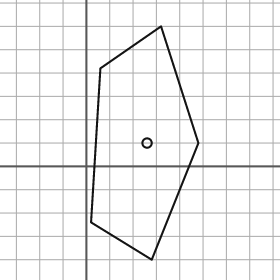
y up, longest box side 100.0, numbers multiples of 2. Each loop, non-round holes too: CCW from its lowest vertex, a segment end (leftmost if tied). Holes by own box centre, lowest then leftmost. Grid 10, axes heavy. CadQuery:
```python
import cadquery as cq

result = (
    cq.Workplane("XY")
    .moveTo(28.0, -40.0)
    .lineTo(48.0, 10.0)
    .lineTo(32.0, 60.0)
    .lineTo(6.0, 42.0)
    .lineTo(2.0, -24.0)
    .close()
    .moveTo(26.0, 10.0)
    .circle(2.0)
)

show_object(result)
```